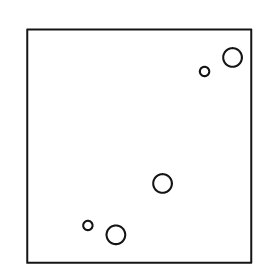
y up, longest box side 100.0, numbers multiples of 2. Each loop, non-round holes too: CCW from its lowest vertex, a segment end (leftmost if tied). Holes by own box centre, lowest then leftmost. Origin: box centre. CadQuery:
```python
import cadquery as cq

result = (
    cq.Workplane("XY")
    .moveTo(-48.0, -50.0)
    .lineTo(48.0, -50.0)
    .lineTo(48.0, 50.0)
    .lineTo(-48.0, 50.0)
    .close()
    .moveTo(-10.0, -38.0)
    .circle(4.0)
    .moveTo(-22.0, -34.0)
    .circle(2.0)
    .moveTo(10.0, -16.0)
    .circle(4.0)
    .moveTo(28.0, 32.0)
    .circle(2.0)
    .moveTo(40.0, 38.0)
    .circle(4.0)
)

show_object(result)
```